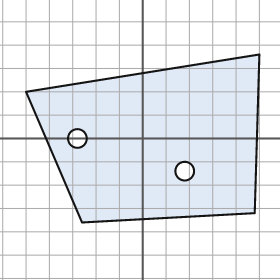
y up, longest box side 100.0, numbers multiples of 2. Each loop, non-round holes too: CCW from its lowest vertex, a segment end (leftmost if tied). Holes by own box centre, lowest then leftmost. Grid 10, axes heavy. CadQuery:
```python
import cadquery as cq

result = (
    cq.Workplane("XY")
    .moveTo(-26.0, -36.0)
    .lineTo(48.0, -32.0)
    .lineTo(50.0, 36.0)
    .lineTo(-50.0, 20.0)
    .close()
    .moveTo(18.0, -14.0)
    .circle(4.0)
    .moveTo(-28.0, 0.0)
    .circle(4.0)
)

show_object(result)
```